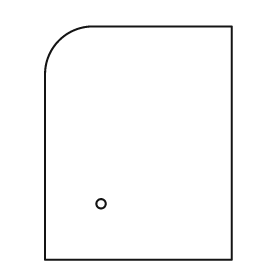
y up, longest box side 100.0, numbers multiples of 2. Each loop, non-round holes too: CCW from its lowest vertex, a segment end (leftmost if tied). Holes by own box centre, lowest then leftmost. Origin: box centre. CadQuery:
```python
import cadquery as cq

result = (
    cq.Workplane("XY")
    .moveTo(-40.0, -50.0)
    .lineTo(40.0, -50.0)
    .lineTo(40.0, 50.0)
    .lineTo(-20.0, 50.0)
    .threePointArc((-34.0, 44.0), (-40.0, 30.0))
    .close()
    .moveTo(-16.0, -26.0)
    .circle(2.0)
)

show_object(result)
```